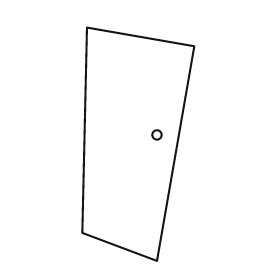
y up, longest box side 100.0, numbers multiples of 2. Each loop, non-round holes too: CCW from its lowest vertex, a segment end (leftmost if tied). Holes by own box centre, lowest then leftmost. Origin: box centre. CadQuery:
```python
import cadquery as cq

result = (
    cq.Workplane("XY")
    .moveTo(8.0, -50.0)
    .lineTo(24.0, 42.0)
    .lineTo(-22.0, 50.0)
    .lineTo(-24.0, -38.0)
    .close()
    .moveTo(8.0, 4.0)
    .circle(2.0)
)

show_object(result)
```